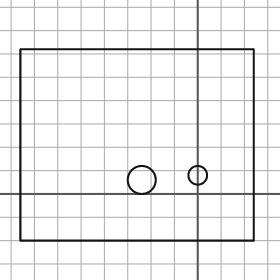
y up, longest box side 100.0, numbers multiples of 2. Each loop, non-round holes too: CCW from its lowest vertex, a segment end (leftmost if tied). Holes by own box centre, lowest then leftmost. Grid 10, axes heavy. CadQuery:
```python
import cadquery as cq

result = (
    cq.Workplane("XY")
    .moveTo(-76.0, -20.0)
    .lineTo(24.0, -20.0)
    .lineTo(24.0, 62.0)
    .lineTo(-76.0, 62.0)
    .close()
    .moveTo(-24.0, 6.0)
    .circle(6.0)
    .moveTo(0.0, 8.0)
    .circle(4.0)
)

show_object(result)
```